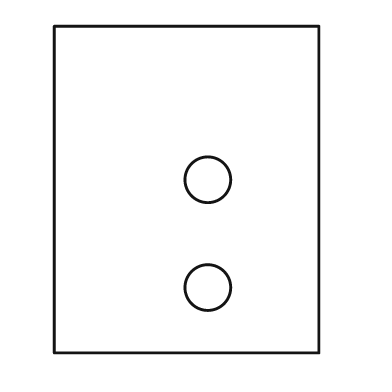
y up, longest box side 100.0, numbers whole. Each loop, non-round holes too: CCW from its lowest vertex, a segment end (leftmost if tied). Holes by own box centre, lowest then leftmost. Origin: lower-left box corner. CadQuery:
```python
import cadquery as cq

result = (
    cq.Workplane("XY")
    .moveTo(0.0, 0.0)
    .lineTo(81.0, 0.0)
    .lineTo(81.0, 100.0)
    .lineTo(0.0, 100.0)
    .close()
    .moveTo(47.0, 20.0)
    .circle(7.0)
    .moveTo(47.0, 53.0)
    .circle(7.0)
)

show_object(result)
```